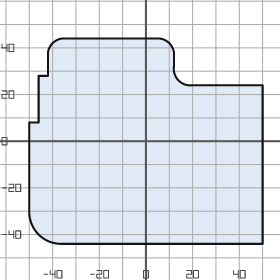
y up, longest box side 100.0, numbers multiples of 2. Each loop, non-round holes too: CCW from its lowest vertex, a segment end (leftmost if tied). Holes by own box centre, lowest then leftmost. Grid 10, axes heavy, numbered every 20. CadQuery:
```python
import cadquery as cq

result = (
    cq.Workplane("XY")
    .moveTo(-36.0, -44.0)
    .lineTo(50.0, -44.0)
    .lineTo(50.0, 24.0)
    .lineTo(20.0, 24.0)
    .threePointArc((14.0, 26.0), (12.0, 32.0))
    .lineTo(12.0, 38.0)
    .threePointArc((10.0, 42.0), (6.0, 44.0))
    .lineTo(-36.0, 44.0)
    .threePointArc((-40.0, 42.0), (-42.0, 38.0))
    .lineTo(-42.0, 28.0)
    .lineTo(-46.0, 28.0)
    .lineTo(-46.0, 8.0)
    .lineTo(-50.0, 8.0)
    .lineTo(-50.0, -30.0)
    .threePointArc((-46.0, -40.0), (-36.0, -44.0))
    .close()
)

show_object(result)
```